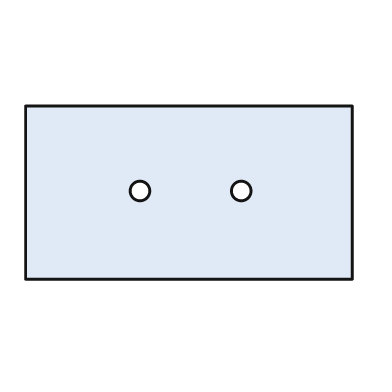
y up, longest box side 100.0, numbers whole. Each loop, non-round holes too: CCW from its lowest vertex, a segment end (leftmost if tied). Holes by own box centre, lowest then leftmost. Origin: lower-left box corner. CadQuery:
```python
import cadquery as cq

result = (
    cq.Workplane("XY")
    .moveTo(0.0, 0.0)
    .lineTo(100.0, 0.0)
    .lineTo(100.0, 53.0)
    .lineTo(0.0, 53.0)
    .close()
    .moveTo(35.0, 27.0)
    .circle(3.0)
    .moveTo(66.0, 27.0)
    .circle(3.0)
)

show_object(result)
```